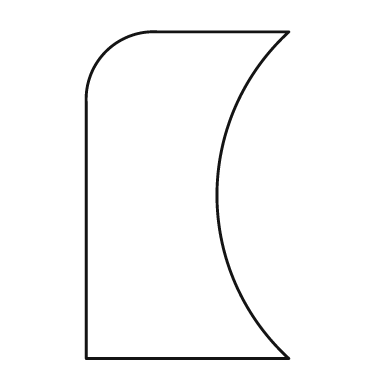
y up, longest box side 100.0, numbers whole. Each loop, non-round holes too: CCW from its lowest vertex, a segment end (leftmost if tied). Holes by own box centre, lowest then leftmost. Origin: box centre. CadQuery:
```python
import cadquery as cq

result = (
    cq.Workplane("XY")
    .moveTo(-31.0, -50.0)
    .lineTo(31.0, -50.0)
    .threePointArc((9.0, 0.0), (31.0, 50.0))
    .lineTo(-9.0, 50.0)
    .threePointArc((-25.0, 44.0), (-31.0, 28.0))
    .close()
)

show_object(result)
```